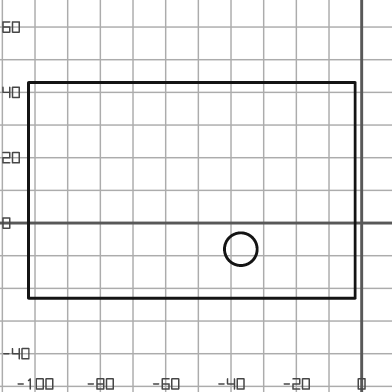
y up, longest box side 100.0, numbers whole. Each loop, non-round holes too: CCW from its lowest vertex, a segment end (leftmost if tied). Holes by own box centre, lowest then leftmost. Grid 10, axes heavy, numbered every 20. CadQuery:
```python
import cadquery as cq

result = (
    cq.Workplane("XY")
    .moveTo(-102.0, -23.0)
    .lineTo(-2.0, -23.0)
    .lineTo(-2.0, 43.0)
    .lineTo(-102.0, 43.0)
    .close()
    .moveTo(-37.0, -8.0)
    .circle(5.0)
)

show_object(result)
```